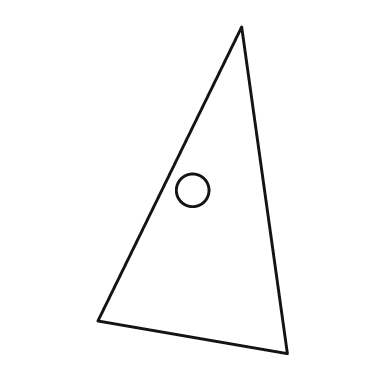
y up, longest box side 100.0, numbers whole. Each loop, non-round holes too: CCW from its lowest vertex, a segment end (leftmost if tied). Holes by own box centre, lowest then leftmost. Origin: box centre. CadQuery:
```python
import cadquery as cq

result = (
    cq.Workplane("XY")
    .moveTo(29.0, -50.0)
    .lineTo(15.0, 50.0)
    .lineTo(-29.0, -40.0)
    .close()
    .moveTo(0.0, 0.0)
    .circle(5.0)
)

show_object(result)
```